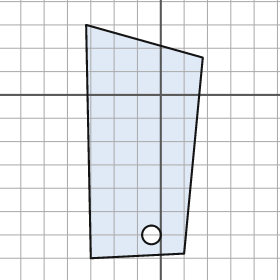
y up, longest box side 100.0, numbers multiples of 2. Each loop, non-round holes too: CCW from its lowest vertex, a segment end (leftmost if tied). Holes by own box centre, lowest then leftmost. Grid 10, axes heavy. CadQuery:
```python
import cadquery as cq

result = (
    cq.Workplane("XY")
    .moveTo(-30.0, -70.0)
    .lineTo(10.0, -68.0)
    .lineTo(18.0, 16.0)
    .lineTo(-32.0, 30.0)
    .close()
    .moveTo(-4.0, -60.0)
    .circle(4.0)
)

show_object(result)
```